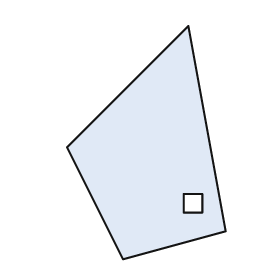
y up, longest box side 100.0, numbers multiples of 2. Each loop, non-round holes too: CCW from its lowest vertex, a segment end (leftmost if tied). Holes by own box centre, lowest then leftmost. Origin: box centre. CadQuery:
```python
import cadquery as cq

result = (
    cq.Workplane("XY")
    .moveTo(-10.0, -50.0)
    .lineTo(34.0, -38.0)
    .lineTo(18.0, 50.0)
    .lineTo(-34.0, -2.0)
    .close()
    .moveTo(16.0, -30.0)
    .lineTo(24.0, -30.0)
    .lineTo(24.0, -22.0)
    .lineTo(16.0, -22.0)
    .close()
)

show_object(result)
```